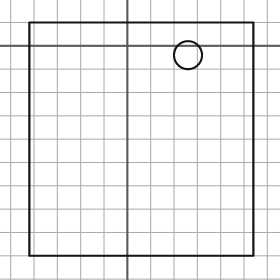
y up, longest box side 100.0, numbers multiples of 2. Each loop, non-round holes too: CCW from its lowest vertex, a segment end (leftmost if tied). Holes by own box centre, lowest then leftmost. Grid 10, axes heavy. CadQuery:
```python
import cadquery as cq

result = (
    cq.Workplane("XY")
    .moveTo(-42.0, -90.0)
    .lineTo(54.0, -90.0)
    .lineTo(54.0, 10.0)
    .lineTo(-42.0, 10.0)
    .close()
    .moveTo(26.0, -4.0)
    .circle(6.0)
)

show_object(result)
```